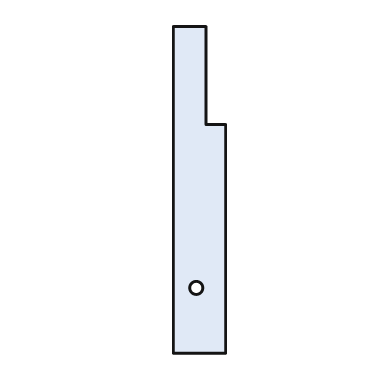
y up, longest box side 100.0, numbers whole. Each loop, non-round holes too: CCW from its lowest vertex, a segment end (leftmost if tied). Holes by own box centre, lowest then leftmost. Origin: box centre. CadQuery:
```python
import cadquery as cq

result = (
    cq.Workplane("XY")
    .moveTo(-8.0, -50.0)
    .lineTo(8.0, -50.0)
    .lineTo(8.0, 20.0)
    .lineTo(2.0, 20.0)
    .lineTo(2.0, 50.0)
    .lineTo(-8.0, 50.0)
    .close()
    .moveTo(-1.0, -30.0)
    .circle(2.0)
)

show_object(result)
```